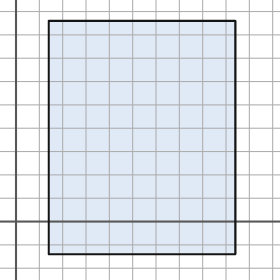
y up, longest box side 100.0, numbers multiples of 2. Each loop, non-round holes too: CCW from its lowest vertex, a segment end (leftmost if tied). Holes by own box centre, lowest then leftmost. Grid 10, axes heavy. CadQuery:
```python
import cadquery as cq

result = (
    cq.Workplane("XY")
    .moveTo(14.0, -14.0)
    .lineTo(94.0, -14.0)
    .lineTo(94.0, 86.0)
    .lineTo(14.0, 86.0)
    .close()
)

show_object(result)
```